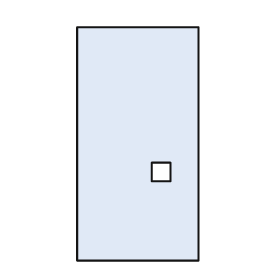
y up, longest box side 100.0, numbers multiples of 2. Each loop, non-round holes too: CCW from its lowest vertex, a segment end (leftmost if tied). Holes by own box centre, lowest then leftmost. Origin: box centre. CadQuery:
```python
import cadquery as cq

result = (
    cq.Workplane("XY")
    .moveTo(-26.0, -50.0)
    .lineTo(26.0, -50.0)
    .lineTo(26.0, 50.0)
    .lineTo(-26.0, 50.0)
    .close()
    .moveTo(6.0, -16.0)
    .lineTo(14.0, -16.0)
    .lineTo(14.0, -8.0)
    .lineTo(6.0, -8.0)
    .close()
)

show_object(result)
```